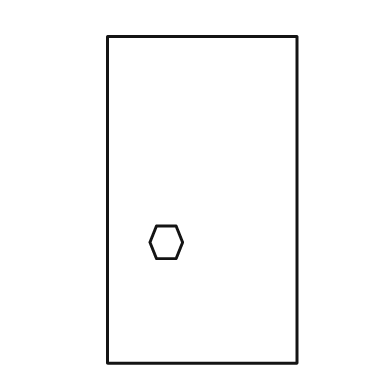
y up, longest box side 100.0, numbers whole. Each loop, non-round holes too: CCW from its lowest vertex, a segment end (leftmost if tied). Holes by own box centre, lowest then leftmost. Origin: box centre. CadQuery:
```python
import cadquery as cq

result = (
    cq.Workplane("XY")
    .moveTo(-29.0, -50.0)
    .lineTo(29.0, -50.0)
    .lineTo(29.0, 50.0)
    .lineTo(-29.0, 50.0)
    .close()
    .moveTo(-14.0, -18.0)
    .lineTo(-8.0, -18.0)
    .lineTo(-6.0, -13.0)
    .lineTo(-8.0, -8.0)
    .lineTo(-14.0, -8.0)
    .lineTo(-16.0, -13.0)
    .close()
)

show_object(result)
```